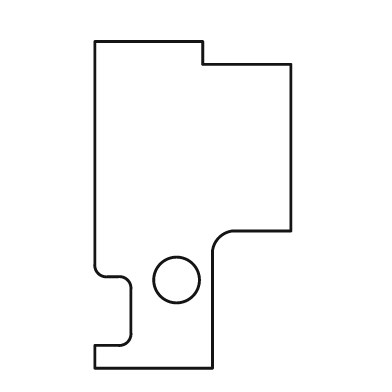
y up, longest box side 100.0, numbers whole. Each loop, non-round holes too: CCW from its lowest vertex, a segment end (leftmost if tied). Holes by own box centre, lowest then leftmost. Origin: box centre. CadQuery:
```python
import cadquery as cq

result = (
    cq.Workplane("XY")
    .moveTo(-30.0, -50.0)
    .lineTo(6.0, -50.0)
    .lineTo(6.0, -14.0)
    .threePointArc((8.0, -10.0), (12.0, -8.0))
    .lineTo(30.0, -8.0)
    .lineTo(30.0, 43.0)
    .lineTo(3.0, 43.0)
    .lineTo(3.0, 50.0)
    .lineTo(-30.0, 50.0)
    .lineTo(-30.0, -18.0)
    .threePointArc((-29.0, -21.0), (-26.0, -22.0))
    .lineTo(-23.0, -22.0)
    .threePointArc((-20.0, -23.0), (-19.0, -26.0))
    .lineTo(-19.0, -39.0)
    .threePointArc((-20.0, -42.0), (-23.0, -43.0))
    .lineTo(-30.0, -43.0)
    .close()
    .moveTo(-5.0, -23.0)
    .circle(7.0)
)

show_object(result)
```